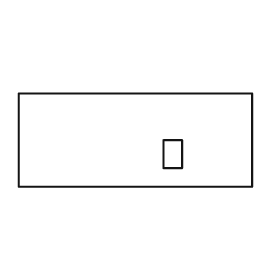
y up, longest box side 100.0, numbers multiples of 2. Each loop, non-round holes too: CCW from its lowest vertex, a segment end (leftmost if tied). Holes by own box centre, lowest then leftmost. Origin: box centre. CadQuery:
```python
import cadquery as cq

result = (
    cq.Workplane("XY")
    .moveTo(-50.0, -20.0)
    .lineTo(50.0, -20.0)
    .lineTo(50.0, 20.0)
    .lineTo(-50.0, 20.0)
    .close()
    .moveTo(12.0, -12.0)
    .lineTo(20.0, -12.0)
    .lineTo(20.0, 0.0)
    .lineTo(12.0, 0.0)
    .close()
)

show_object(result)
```